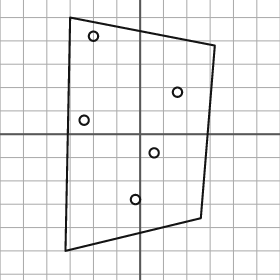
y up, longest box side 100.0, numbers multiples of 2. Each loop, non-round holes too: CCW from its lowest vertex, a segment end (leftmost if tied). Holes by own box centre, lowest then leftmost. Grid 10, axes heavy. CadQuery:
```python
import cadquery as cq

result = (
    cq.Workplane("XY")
    .moveTo(-32.0, -50.0)
    .lineTo(26.0, -36.0)
    .lineTo(32.0, 38.0)
    .lineTo(-30.0, 50.0)
    .close()
    .moveTo(-2.0, -28.0)
    .circle(2.0)
    .moveTo(6.0, -8.0)
    .circle(2.0)
    .moveTo(-24.0, 6.0)
    .circle(2.0)
    .moveTo(16.0, 18.0)
    .circle(2.0)
    .moveTo(-20.0, 42.0)
    .circle(2.0)
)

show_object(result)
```